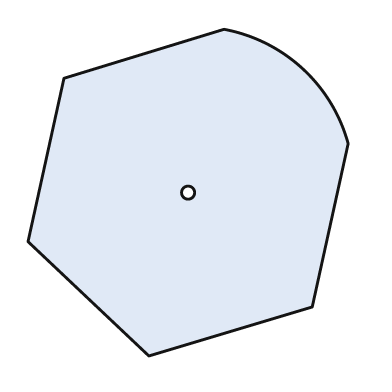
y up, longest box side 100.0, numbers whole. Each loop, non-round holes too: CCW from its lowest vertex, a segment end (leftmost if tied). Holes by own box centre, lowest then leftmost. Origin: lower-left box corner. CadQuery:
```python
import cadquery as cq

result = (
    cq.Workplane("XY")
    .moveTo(37.0, 0.0)
    .lineTo(87.0, 15.0)
    .lineTo(98.0, 65.0)
    .threePointArc((84.0, 88.0), (60.0, 100.0))
    .lineTo(11.0, 85.0)
    .lineTo(0.0, 35.0)
    .close()
    .moveTo(49.0, 50.0)
    .circle(2.0)
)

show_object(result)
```